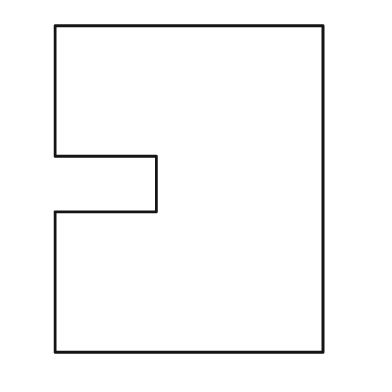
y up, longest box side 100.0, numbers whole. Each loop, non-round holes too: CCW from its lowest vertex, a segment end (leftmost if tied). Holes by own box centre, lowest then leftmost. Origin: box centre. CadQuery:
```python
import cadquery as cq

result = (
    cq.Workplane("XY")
    .moveTo(-41.0, -50.0)
    .lineTo(41.0, -50.0)
    .lineTo(41.0, 50.0)
    .lineTo(-41.0, 50.0)
    .lineTo(-41.0, 10.0)
    .lineTo(-10.0, 10.0)
    .lineTo(-10.0, -7.0)
    .lineTo(-41.0, -7.0)
    .close()
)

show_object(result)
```